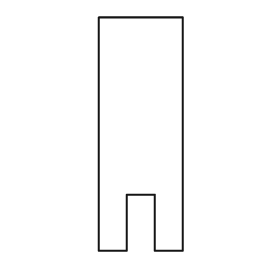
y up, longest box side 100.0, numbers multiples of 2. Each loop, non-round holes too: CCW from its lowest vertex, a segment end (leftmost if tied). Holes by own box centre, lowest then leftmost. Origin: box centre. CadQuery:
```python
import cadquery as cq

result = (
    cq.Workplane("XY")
    .moveTo(-18.0, -50.0)
    .lineTo(-6.0, -50.0)
    .lineTo(-6.0, -26.0)
    .lineTo(6.0, -26.0)
    .lineTo(6.0, -50.0)
    .lineTo(18.0, -50.0)
    .lineTo(18.0, 50.0)
    .lineTo(-18.0, 50.0)
    .close()
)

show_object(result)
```